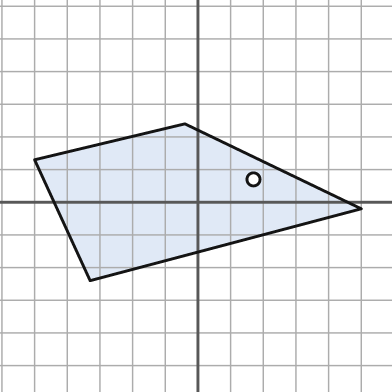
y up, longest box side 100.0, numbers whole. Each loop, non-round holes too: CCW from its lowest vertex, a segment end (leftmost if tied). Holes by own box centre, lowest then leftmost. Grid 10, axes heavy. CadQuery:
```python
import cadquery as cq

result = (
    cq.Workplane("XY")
    .moveTo(-33.0, -24.0)
    .lineTo(50.0, -2.0)
    .lineTo(-4.0, 24.0)
    .lineTo(-50.0, 13.0)
    .close()
    .moveTo(17.0, 7.0)
    .circle(2.0)
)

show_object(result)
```